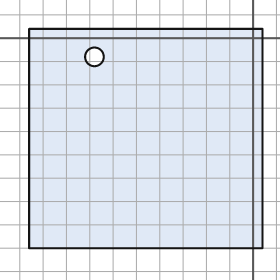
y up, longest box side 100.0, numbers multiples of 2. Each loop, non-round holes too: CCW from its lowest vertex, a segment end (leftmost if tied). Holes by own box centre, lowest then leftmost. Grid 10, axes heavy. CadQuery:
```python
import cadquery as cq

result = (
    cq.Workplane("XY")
    .moveTo(-96.0, -90.0)
    .lineTo(4.0, -90.0)
    .lineTo(4.0, 4.0)
    .lineTo(-96.0, 4.0)
    .close()
    .moveTo(-68.0, -8.0)
    .circle(4.0)
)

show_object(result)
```